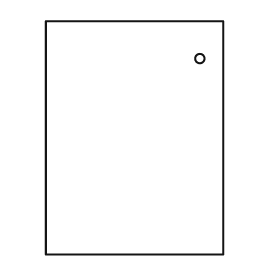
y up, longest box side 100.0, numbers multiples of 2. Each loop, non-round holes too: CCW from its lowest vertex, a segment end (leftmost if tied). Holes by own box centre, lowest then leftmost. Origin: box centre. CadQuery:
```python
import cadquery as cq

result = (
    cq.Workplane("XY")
    .moveTo(-38.0, -50.0)
    .lineTo(38.0, -50.0)
    .lineTo(38.0, 50.0)
    .lineTo(-38.0, 50.0)
    .close()
    .moveTo(28.0, 34.0)
    .circle(2.0)
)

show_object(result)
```